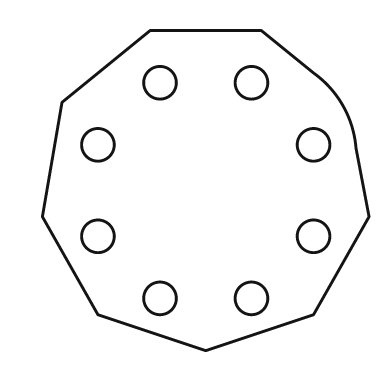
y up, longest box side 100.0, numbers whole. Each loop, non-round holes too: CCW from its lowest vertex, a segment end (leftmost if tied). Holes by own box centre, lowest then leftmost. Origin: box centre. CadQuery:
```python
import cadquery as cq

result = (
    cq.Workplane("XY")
    .moveTo(0.0, -49.0)
    .lineTo(33.0, -38.0)
    .lineTo(50.0, -8.0)
    .lineTo(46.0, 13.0)
    .threePointArc((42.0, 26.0), (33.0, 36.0))
    .lineTo(17.0, 49.0)
    .lineTo(-17.0, 49.0)
    .lineTo(-44.0, 27.0)
    .lineTo(-50.0, -8.0)
    .lineTo(-33.0, -38.0)
    .close()
    .moveTo(-14.0, -33.0)
    .circle(5.0)
    .moveTo(14.0, -33.0)
    .circle(5.0)
    .moveTo(-33.0, -14.0)
    .circle(5.0)
    .moveTo(33.0, -14.0)
    .circle(5.0)
    .moveTo(-33.0, 14.0)
    .circle(5.0)
    .moveTo(33.0, 14.0)
    .circle(5.0)
    .moveTo(-14.0, 33.0)
    .circle(5.0)
    .moveTo(14.0, 33.0)
    .circle(5.0)
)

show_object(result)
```